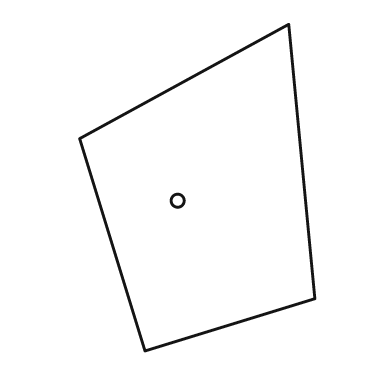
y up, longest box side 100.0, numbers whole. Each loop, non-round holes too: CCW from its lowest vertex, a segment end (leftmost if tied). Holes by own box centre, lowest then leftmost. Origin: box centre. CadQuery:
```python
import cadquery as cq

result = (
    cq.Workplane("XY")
    .moveTo(-16.0, -50.0)
    .lineTo(36.0, -34.0)
    .lineTo(28.0, 50.0)
    .lineTo(-36.0, 15.0)
    .close()
    .moveTo(-6.0, -4.0)
    .circle(2.0)
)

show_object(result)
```